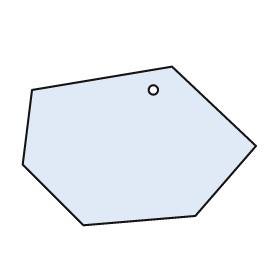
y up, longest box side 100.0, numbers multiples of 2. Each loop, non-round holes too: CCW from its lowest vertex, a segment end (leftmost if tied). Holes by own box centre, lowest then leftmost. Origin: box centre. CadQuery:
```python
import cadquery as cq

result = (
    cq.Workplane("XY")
    .moveTo(-24.0, -34.0)
    .lineTo(24.0, -30.0)
    .lineTo(50.0, 0.0)
    .lineTo(14.0, 34.0)
    .lineTo(-46.0, 24.0)
    .lineTo(-50.0, -8.0)
    .close()
    .moveTo(6.0, 24.0)
    .circle(2.0)
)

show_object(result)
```